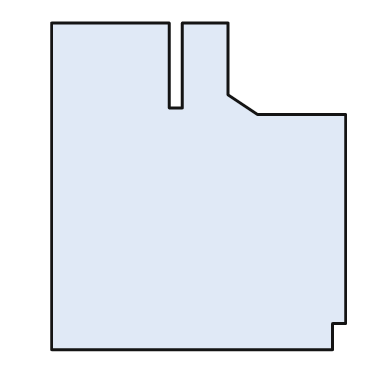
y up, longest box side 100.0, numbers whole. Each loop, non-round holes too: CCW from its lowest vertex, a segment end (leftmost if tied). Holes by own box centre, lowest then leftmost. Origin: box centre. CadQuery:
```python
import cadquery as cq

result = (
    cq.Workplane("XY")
    .moveTo(-45.0, -50.0)
    .lineTo(41.0, -50.0)
    .lineTo(41.0, -42.0)
    .lineTo(45.0, -42.0)
    .lineTo(45.0, 22.0)
    .lineTo(18.0, 22.0)
    .lineTo(9.0, 28.0)
    .lineTo(9.0, 50.0)
    .lineTo(-5.0, 50.0)
    .lineTo(-5.0, 24.0)
    .lineTo(-9.0, 24.0)
    .lineTo(-9.0, 50.0)
    .lineTo(-45.0, 50.0)
    .close()
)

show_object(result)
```